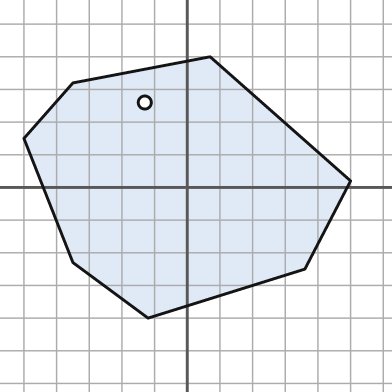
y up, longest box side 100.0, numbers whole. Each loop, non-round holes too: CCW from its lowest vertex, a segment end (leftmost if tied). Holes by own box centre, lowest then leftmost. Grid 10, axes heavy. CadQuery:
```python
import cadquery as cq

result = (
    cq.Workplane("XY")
    .moveTo(-12.0, -40.0)
    .lineTo(36.0, -25.0)
    .lineTo(50.0, 2.0)
    .lineTo(7.0, 40.0)
    .lineTo(-35.0, 32.0)
    .lineTo(-50.0, 15.0)
    .lineTo(-35.0, -23.0)
    .close()
    .moveTo(-13.0, 26.0)
    .circle(2.0)
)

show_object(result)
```